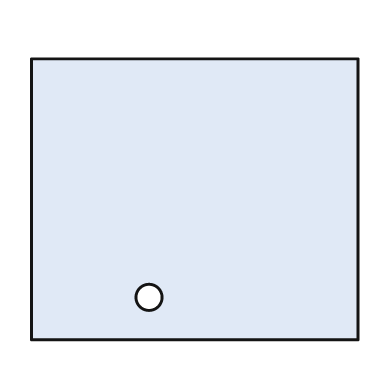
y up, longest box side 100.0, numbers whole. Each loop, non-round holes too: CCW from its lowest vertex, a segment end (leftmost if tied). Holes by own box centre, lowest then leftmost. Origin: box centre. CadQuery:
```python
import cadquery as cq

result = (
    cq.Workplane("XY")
    .moveTo(-50.0, -43.0)
    .lineTo(50.0, -43.0)
    .lineTo(50.0, 43.0)
    .lineTo(-50.0, 43.0)
    .close()
    .moveTo(-14.0, -30.0)
    .circle(4.0)
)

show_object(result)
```